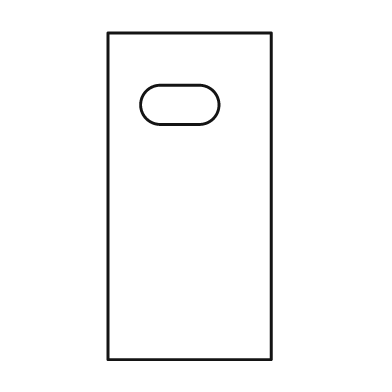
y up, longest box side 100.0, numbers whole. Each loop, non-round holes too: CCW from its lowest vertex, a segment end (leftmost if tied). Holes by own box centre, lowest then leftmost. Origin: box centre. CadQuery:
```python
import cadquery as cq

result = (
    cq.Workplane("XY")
    .moveTo(-25.0, -50.0)
    .lineTo(25.0, -50.0)
    .lineTo(25.0, 50.0)
    .lineTo(-25.0, 50.0)
    .close()
    .moveTo(-9.0, 22.0)
    .lineTo(3.0, 22.0)
    .threePointArc((9.0, 28.0), (3.0, 34.0))
    .lineTo(-9.0, 34.0)
    .threePointArc((-15.0, 28.0), (-9.0, 22.0))
    .close()
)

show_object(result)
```